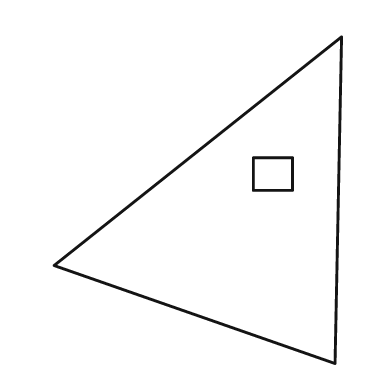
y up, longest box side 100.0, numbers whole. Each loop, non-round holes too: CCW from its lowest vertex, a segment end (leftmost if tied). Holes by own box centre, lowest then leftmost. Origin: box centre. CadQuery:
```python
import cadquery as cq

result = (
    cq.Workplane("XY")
    .moveTo(42.0, -50.0)
    .lineTo(44.0, 50.0)
    .lineTo(-44.0, -20.0)
    .close()
    .moveTo(17.0, 3.0)
    .lineTo(29.0, 3.0)
    .lineTo(29.0, 13.0)
    .lineTo(17.0, 13.0)
    .close()
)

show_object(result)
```